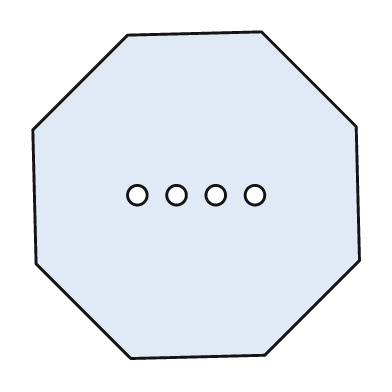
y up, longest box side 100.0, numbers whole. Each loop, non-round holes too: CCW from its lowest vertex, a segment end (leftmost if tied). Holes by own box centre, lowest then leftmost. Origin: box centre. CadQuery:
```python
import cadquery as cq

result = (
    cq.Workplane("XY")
    .moveTo(-20.0, -50.0)
    .lineTo(21.0, -49.0)
    .lineTo(50.0, -20.0)
    .lineTo(49.0, 21.0)
    .lineTo(20.0, 50.0)
    .lineTo(-21.0, 49.0)
    .lineTo(-50.0, 20.0)
    .lineTo(-49.0, -21.0)
    .close()
    .moveTo(-18.0, 0.0)
    .circle(3.0)
    .moveTo(-6.0, 0.0)
    .circle(3.0)
    .moveTo(6.0, 0.0)
    .circle(3.0)
    .moveTo(18.0, 0.0)
    .circle(3.0)
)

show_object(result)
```